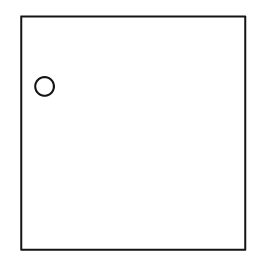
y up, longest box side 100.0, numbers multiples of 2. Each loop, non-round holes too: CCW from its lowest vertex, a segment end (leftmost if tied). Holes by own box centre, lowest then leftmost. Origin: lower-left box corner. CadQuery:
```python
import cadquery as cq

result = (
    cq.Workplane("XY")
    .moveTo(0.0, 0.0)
    .lineTo(96.0, 0.0)
    .lineTo(96.0, 100.0)
    .lineTo(0.0, 100.0)
    .close()
    .moveTo(10.0, 70.0)
    .circle(4.0)
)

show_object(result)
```